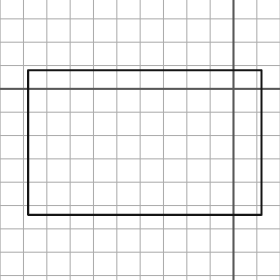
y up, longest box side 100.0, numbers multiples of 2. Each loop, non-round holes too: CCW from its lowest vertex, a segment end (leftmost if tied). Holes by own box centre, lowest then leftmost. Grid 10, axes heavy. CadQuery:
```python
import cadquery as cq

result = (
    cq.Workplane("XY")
    .moveTo(-88.0, -54.0)
    .lineTo(12.0, -54.0)
    .lineTo(12.0, 8.0)
    .lineTo(-88.0, 8.0)
    .close()
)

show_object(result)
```